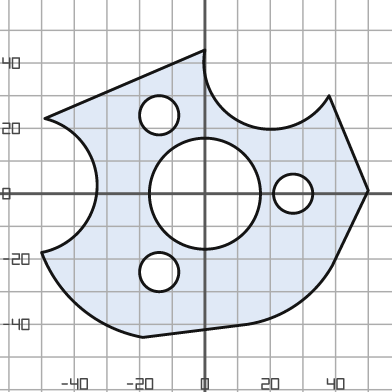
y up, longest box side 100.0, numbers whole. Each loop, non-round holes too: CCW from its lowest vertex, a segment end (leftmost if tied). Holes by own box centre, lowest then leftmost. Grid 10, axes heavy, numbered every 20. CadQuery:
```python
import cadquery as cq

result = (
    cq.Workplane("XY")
    .moveTo(-19.0, -44.0)
    .lineTo(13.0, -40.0)
    .threePointArc((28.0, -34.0), (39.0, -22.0))
    .lineTo(50.0, 1.0)
    .lineTo(38.0, 30.0)
    .threePointArc((13.0, 21.0), (0.0, 44.0))
    .lineTo(-49.0, 23.0)
    .threePointArc((-33.0, 2.0), (-50.0, -18.0))
    .threePointArc((-38.0, -35.0), (-19.0, -44.0))
    .close()
    .moveTo(-14.0, -24.0)
    .circle(6.0)
    .moveTo(0.0, 0.0)
    .circle(17.0)
    .moveTo(27.0, 0.0)
    .circle(6.0)
    .moveTo(-14.0, 24.0)
    .circle(6.0)
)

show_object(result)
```